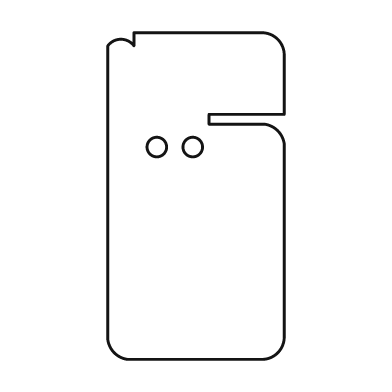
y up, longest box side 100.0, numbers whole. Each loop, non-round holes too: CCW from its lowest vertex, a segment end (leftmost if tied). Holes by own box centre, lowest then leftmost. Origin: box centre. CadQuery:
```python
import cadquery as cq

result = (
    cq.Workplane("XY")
    .moveTo(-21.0, -50.0)
    .lineTo(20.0, -50.0)
    .threePointArc((25.0, -48.0), (27.0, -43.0))
    .lineTo(27.0, 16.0)
    .threePointArc((25.0, 20.0), (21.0, 22.0))
    .lineTo(4.0, 22.0)
    .lineTo(4.0, 25.0)
    .lineTo(27.0, 25.0)
    .lineTo(27.0, 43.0)
    .threePointArc((25.0, 48.0), (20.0, 50.0))
    .lineTo(-19.0, 50.0)
    .lineTo(-19.0, 46.0)
    .threePointArc((-23.0, 48.0), (-27.0, 46.0))
    .lineTo(-27.0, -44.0)
    .threePointArc((-25.0, -48.0), (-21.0, -50.0))
    .close()
    .moveTo(-12.0, 15.0)
    .circle(3.0)
    .moveTo(-1.0, 15.0)
    .circle(3.0)
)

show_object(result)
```